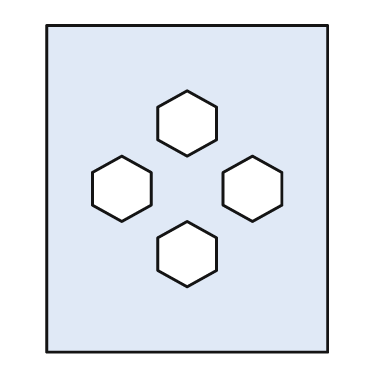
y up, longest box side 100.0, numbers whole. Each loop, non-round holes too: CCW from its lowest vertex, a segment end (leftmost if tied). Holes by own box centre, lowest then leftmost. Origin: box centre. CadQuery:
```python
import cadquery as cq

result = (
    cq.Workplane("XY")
    .moveTo(-43.0, -50.0)
    .lineTo(43.0, -50.0)
    .lineTo(43.0, 50.0)
    .lineTo(-43.0, 50.0)
    .close()
    .moveTo(0.0, -30.0)
    .lineTo(9.0, -25.0)
    .lineTo(9.0, -15.0)
    .lineTo(0.0, -10.0)
    .lineTo(-9.0, -15.0)
    .lineTo(-9.0, -25.0)
    .close()
    .moveTo(-20.0, -10.0)
    .lineTo(-11.0, -5.0)
    .lineTo(-11.0, 5.0)
    .lineTo(-20.0, 10.0)
    .lineTo(-29.0, 5.0)
    .lineTo(-29.0, -5.0)
    .close()
    .moveTo(20.0, -10.0)
    .lineTo(29.0, -5.0)
    .lineTo(29.0, 5.0)
    .lineTo(20.0, 10.0)
    .lineTo(11.0, 5.0)
    .lineTo(11.0, -5.0)
    .close()
    .moveTo(0.0, 10.0)
    .lineTo(9.0, 15.0)
    .lineTo(9.0, 25.0)
    .lineTo(0.0, 30.0)
    .lineTo(-9.0, 25.0)
    .lineTo(-9.0, 15.0)
    .close()
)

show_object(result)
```